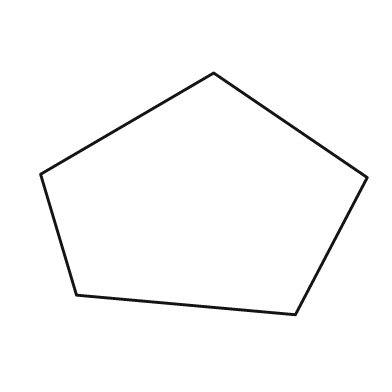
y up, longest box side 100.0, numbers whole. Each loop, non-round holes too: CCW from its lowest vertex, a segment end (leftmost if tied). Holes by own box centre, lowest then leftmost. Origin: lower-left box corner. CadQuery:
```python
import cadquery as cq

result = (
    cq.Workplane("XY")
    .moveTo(78.0, 0.0)
    .lineTo(100.0, 42.0)
    .lineTo(53.0, 74.0)
    .lineTo(0.0, 43.0)
    .lineTo(11.0, 6.0)
    .close()
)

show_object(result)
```